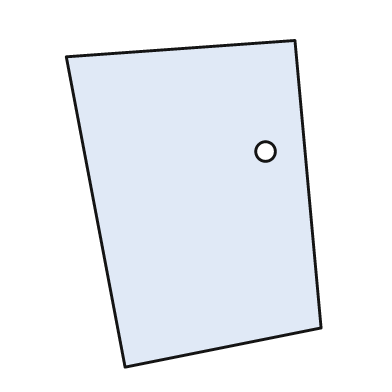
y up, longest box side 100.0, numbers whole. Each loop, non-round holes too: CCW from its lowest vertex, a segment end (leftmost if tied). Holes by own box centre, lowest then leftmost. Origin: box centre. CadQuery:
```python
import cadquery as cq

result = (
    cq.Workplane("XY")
    .moveTo(-21.0, -50.0)
    .lineTo(39.0, -38.0)
    .lineTo(31.0, 50.0)
    .lineTo(-39.0, 45.0)
    .close()
    .moveTo(22.0, 16.0)
    .circle(3.0)
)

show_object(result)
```